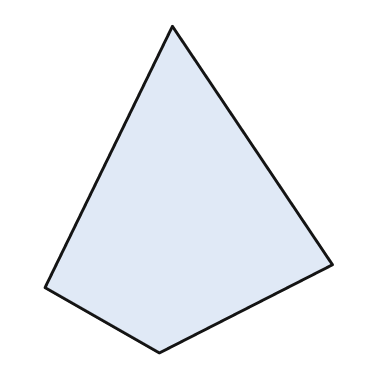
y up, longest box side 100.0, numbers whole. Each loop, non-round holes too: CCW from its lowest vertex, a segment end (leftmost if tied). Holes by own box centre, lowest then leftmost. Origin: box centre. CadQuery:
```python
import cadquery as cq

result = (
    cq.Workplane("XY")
    .moveTo(-9.0, -50.0)
    .lineTo(44.0, -23.0)
    .lineTo(-5.0, 50.0)
    .lineTo(-44.0, -30.0)
    .close()
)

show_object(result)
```